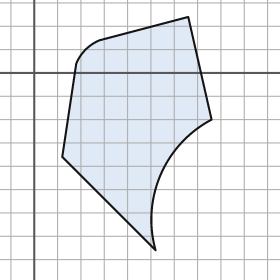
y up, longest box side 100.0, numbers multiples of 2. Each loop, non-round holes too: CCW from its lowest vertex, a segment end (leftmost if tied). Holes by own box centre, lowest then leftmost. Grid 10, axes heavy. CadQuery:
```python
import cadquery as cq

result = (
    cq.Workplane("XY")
    .moveTo(52.0, -76.0)
    .threePointArc((54.0, -44.0), (76.0, -20.0))
    .lineTo(66.0, 24.0)
    .lineTo(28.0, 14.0)
    .threePointArc((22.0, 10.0), (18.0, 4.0))
    .lineTo(12.0, -36.0)
    .close()
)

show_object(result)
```